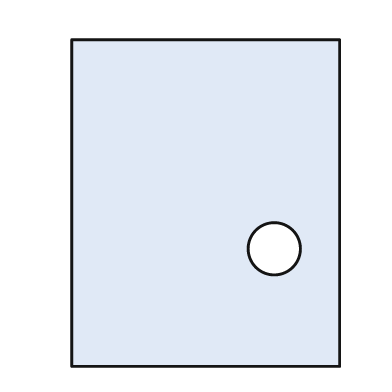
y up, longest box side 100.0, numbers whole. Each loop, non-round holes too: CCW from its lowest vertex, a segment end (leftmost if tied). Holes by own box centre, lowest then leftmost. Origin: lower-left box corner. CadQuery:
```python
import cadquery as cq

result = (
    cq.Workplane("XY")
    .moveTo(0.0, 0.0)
    .lineTo(82.0, 0.0)
    .lineTo(82.0, 100.0)
    .lineTo(0.0, 100.0)
    .close()
    .moveTo(62.0, 36.0)
    .circle(8.0)
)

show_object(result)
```